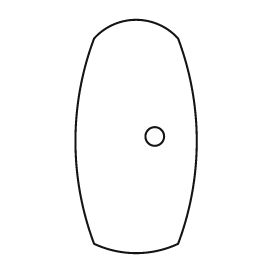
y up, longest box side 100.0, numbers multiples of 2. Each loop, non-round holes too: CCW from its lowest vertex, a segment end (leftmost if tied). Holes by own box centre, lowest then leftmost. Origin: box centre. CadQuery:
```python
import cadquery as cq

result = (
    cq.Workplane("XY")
    .moveTo(-18.0, -46.0)
    .threePointArc((0.0, -50.0), (18.0, -46.0))
    .threePointArc((26.0, -2.0), (18.0, 42.0))
    .threePointArc((0.0, 50.0), (-18.0, 42.0))
    .threePointArc((-26.0, -2.0), (-18.0, -46.0))
    .close()
    .moveTo(8.0, 0.0)
    .circle(4.0)
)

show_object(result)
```